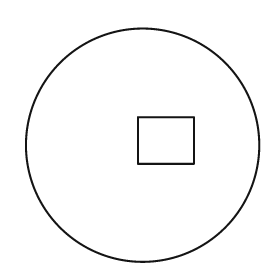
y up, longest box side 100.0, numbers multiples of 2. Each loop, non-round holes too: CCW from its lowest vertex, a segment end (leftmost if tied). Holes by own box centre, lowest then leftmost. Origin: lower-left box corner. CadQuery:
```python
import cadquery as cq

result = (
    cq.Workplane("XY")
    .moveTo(50.0, 50.0)
    .circle(50.0)
    .moveTo(48.0, 42.0)
    .lineTo(72.0, 42.0)
    .lineTo(72.0, 62.0)
    .lineTo(48.0, 62.0)
    .close()
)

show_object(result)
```